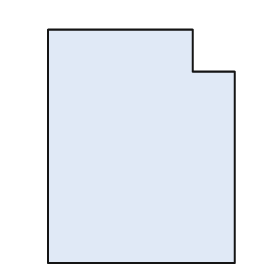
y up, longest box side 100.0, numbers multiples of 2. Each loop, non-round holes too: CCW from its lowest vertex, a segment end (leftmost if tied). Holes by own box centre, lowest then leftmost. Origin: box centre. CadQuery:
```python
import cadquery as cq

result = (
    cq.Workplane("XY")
    .moveTo(-40.0, -50.0)
    .lineTo(40.0, -50.0)
    .lineTo(40.0, 32.0)
    .lineTo(22.0, 32.0)
    .lineTo(22.0, 50.0)
    .lineTo(-40.0, 50.0)
    .close()
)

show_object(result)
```